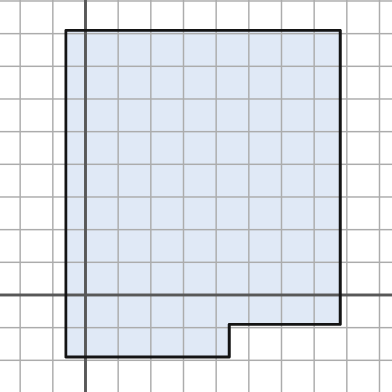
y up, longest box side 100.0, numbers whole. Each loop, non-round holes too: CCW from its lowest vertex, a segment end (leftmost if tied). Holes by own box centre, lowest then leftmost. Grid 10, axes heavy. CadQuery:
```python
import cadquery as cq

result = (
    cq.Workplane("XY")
    .moveTo(-6.0, -19.0)
    .lineTo(44.0, -19.0)
    .lineTo(44.0, -9.0)
    .lineTo(78.0, -9.0)
    .lineTo(78.0, 81.0)
    .lineTo(-6.0, 81.0)
    .close()
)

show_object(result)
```